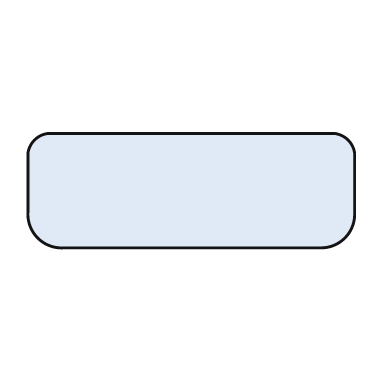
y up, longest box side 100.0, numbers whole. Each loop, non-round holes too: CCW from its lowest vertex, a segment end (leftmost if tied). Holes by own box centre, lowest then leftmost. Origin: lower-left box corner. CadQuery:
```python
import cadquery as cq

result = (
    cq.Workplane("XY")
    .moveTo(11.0, 0.0)
    .lineTo(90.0, 0.0)
    .threePointArc((97.0, 3.0), (100.0, 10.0))
    .lineTo(100.0, 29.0)
    .threePointArc((98.0, 33.0), (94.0, 35.0))
    .lineTo(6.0, 35.0)
    .threePointArc((2.0, 33.0), (0.0, 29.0))
    .lineTo(0.0, 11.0)
    .threePointArc((3.0, 3.0), (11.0, 0.0))
    .close()
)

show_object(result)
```